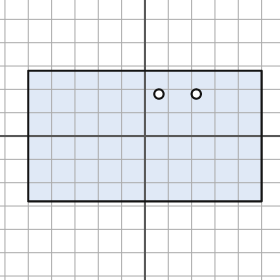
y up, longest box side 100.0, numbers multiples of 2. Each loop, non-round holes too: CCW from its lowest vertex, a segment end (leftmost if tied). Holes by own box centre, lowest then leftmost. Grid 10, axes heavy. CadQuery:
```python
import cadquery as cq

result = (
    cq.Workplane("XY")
    .moveTo(-50.0, -28.0)
    .lineTo(50.0, -28.0)
    .lineTo(50.0, 28.0)
    .lineTo(-50.0, 28.0)
    .close()
    .moveTo(6.0, 18.0)
    .circle(2.0)
    .moveTo(22.0, 18.0)
    .circle(2.0)
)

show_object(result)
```